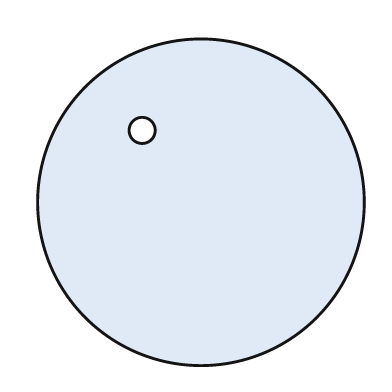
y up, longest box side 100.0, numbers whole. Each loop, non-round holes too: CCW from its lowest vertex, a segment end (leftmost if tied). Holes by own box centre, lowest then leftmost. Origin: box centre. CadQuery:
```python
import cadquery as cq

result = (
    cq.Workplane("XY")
    .moveTo(0.0, 0.0)
    .circle(50.0)
    .moveTo(-18.0, 22.0)
    .circle(4.0)
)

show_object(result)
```